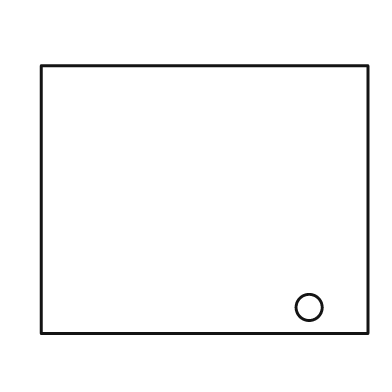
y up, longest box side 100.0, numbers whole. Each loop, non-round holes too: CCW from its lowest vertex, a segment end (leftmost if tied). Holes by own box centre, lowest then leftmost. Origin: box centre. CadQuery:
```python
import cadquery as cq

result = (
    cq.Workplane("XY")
    .moveTo(-50.0, -41.0)
    .lineTo(50.0, -41.0)
    .lineTo(50.0, 41.0)
    .lineTo(-50.0, 41.0)
    .close()
    .moveTo(32.0, -33.0)
    .circle(4.0)
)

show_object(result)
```